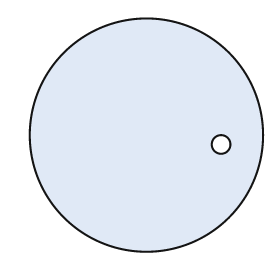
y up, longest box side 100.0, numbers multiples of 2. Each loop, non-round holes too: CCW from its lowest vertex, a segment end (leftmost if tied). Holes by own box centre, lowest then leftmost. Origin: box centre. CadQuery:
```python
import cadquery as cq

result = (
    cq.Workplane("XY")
    .moveTo(0.0, 0.0)
    .circle(50.0)
    .moveTo(32.0, -4.0)
    .circle(4.0)
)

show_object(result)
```